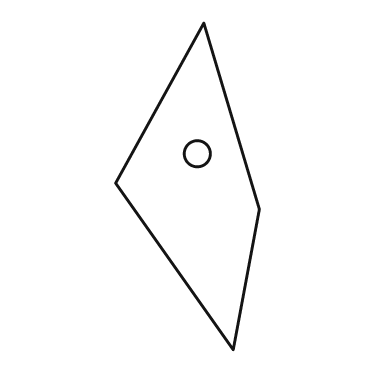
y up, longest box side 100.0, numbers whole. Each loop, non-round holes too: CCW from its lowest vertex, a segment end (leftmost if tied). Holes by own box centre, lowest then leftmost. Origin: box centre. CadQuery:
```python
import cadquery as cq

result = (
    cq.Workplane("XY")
    .moveTo(14.0, -50.0)
    .lineTo(22.0, -7.0)
    .lineTo(5.0, 50.0)
    .lineTo(-22.0, 1.0)
    .close()
    .moveTo(3.0, 10.0)
    .circle(4.0)
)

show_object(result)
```